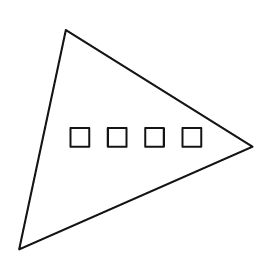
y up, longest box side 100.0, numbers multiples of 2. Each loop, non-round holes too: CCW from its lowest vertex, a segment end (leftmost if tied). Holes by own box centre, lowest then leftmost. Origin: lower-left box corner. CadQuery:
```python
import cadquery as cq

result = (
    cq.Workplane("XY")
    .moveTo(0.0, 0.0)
    .lineTo(100.0, 44.0)
    .lineTo(20.0, 94.0)
    .close()
    .moveTo(22.0, 44.0)
    .lineTo(30.0, 44.0)
    .lineTo(30.0, 52.0)
    .lineTo(22.0, 52.0)
    .close()
    .moveTo(38.0, 44.0)
    .lineTo(46.0, 44.0)
    .lineTo(46.0, 52.0)
    .lineTo(38.0, 52.0)
    .close()
    .moveTo(54.0, 44.0)
    .lineTo(62.0, 44.0)
    .lineTo(62.0, 52.0)
    .lineTo(54.0, 52.0)
    .close()
    .moveTo(70.0, 44.0)
    .lineTo(78.0, 44.0)
    .lineTo(78.0, 52.0)
    .lineTo(70.0, 52.0)
    .close()
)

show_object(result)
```